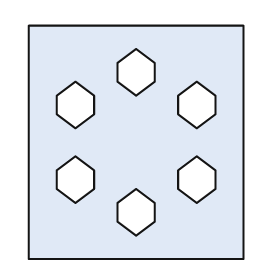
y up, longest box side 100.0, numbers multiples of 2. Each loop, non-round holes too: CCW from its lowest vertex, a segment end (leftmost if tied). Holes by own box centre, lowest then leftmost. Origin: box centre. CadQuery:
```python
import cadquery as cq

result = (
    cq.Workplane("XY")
    .moveTo(-46.0, -50.0)
    .lineTo(46.0, -50.0)
    .lineTo(46.0, 50.0)
    .lineTo(-46.0, 50.0)
    .close()
    .moveTo(0.0, -40.0)
    .lineTo(8.0, -34.0)
    .lineTo(8.0, -26.0)
    .lineTo(0.0, -20.0)
    .lineTo(-8.0, -26.0)
    .lineTo(-8.0, -34.0)
    .close()
    .moveTo(-26.0, -26.0)
    .lineTo(-18.0, -20.0)
    .lineTo(-18.0, -12.0)
    .lineTo(-26.0, -6.0)
    .lineTo(-34.0, -12.0)
    .lineTo(-34.0, -20.0)
    .close()
    .moveTo(26.0, -26.0)
    .lineTo(34.0, -20.0)
    .lineTo(34.0, -12.0)
    .lineTo(26.0, -6.0)
    .lineTo(18.0, -12.0)
    .lineTo(18.0, -20.0)
    .close()
    .moveTo(-26.0, 6.0)
    .lineTo(-18.0, 12.0)
    .lineTo(-18.0, 20.0)
    .lineTo(-26.0, 26.0)
    .lineTo(-34.0, 20.0)
    .lineTo(-34.0, 12.0)
    .close()
    .moveTo(26.0, 6.0)
    .lineTo(34.0, 12.0)
    .lineTo(34.0, 20.0)
    .lineTo(26.0, 26.0)
    .lineTo(18.0, 20.0)
    .lineTo(18.0, 12.0)
    .close()
    .moveTo(0.0, 20.0)
    .lineTo(8.0, 26.0)
    .lineTo(8.0, 34.0)
    .lineTo(0.0, 40.0)
    .lineTo(-8.0, 34.0)
    .lineTo(-8.0, 26.0)
    .close()
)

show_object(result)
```